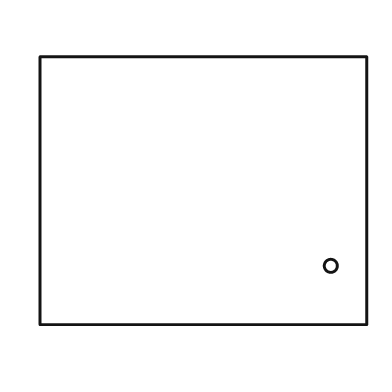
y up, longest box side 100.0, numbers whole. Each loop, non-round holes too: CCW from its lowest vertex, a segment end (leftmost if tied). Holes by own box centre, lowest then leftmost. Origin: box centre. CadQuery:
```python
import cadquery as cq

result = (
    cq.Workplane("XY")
    .moveTo(-50.0, -41.0)
    .lineTo(50.0, -41.0)
    .lineTo(50.0, 41.0)
    .lineTo(-50.0, 41.0)
    .close()
    .moveTo(39.0, -23.0)
    .circle(2.0)
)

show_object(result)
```